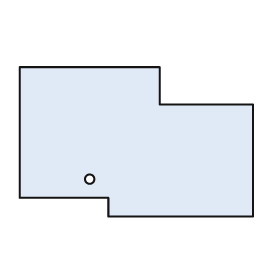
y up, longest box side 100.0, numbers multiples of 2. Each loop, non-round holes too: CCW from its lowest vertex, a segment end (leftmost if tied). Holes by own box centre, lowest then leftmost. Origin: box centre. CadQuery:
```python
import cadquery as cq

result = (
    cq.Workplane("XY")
    .moveTo(-12.0, -32.0)
    .lineTo(50.0, -32.0)
    .lineTo(50.0, 16.0)
    .lineTo(10.0, 16.0)
    .lineTo(10.0, 32.0)
    .lineTo(-50.0, 32.0)
    .lineTo(-50.0, -24.0)
    .lineTo(-12.0, -24.0)
    .close()
    .moveTo(-20.0, -16.0)
    .circle(2.0)
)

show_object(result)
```